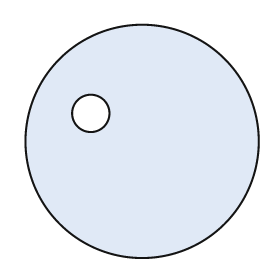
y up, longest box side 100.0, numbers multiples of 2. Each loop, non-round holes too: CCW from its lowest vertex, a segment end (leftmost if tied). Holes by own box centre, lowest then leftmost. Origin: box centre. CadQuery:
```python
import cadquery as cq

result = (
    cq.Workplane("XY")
    .moveTo(0.0, 0.0)
    .circle(50.0)
    .moveTo(-22.0, 12.0)
    .circle(8.0)
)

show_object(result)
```